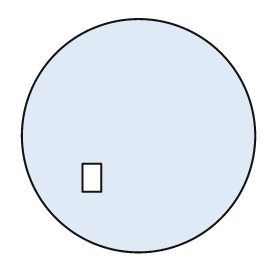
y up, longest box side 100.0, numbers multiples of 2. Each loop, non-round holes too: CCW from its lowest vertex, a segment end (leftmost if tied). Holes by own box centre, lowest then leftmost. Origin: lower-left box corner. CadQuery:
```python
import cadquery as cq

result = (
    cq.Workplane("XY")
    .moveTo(50.0, 50.0)
    .circle(50.0)
    .moveTo(26.0, 26.0)
    .lineTo(34.0, 26.0)
    .lineTo(34.0, 38.0)
    .lineTo(26.0, 38.0)
    .close()
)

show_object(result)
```